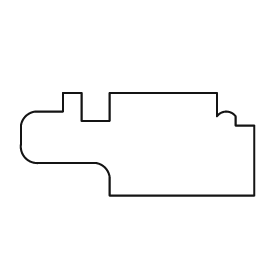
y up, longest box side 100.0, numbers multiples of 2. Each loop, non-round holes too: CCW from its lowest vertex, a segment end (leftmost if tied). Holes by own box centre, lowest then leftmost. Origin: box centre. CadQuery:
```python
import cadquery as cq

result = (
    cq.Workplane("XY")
    .moveTo(-12.0, -22.0)
    .lineTo(50.0, -22.0)
    .lineTo(50.0, 8.0)
    .lineTo(42.0, 8.0)
    .lineTo(42.0, 12.0)
    .threePointArc((38.0, 14.0), (34.0, 12.0))
    .lineTo(34.0, 22.0)
    .lineTo(-12.0, 22.0)
    .lineTo(-12.0, 10.0)
    .lineTo(-24.0, 10.0)
    .lineTo(-24.0, 22.0)
    .lineTo(-32.0, 22.0)
    .lineTo(-32.0, 14.0)
    .lineTo(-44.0, 14.0)
    .threePointArc((-48.0, 12.0), (-50.0, 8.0))
    .lineTo(-50.0, 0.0)
    .threePointArc((-48.0, -6.0), (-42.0, -8.0))
    .lineTo(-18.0, -8.0)
    .threePointArc((-14.0, -10.0), (-12.0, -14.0))
    .close()
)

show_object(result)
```